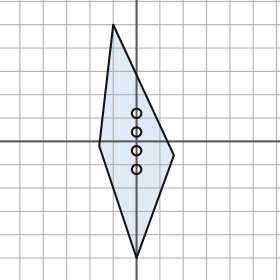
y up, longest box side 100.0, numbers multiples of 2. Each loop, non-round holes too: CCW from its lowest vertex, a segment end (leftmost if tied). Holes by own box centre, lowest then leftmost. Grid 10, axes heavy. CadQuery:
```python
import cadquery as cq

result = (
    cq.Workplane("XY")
    .moveTo(0.0, -50.0)
    .lineTo(16.0, -6.0)
    .lineTo(-10.0, 50.0)
    .lineTo(-16.0, -2.0)
    .close()
    .moveTo(0.0, -12.0)
    .circle(2.0)
    .moveTo(0.0, -4.0)
    .circle(2.0)
    .moveTo(0.0, 4.0)
    .circle(2.0)
    .moveTo(0.0, 12.0)
    .circle(2.0)
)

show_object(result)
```